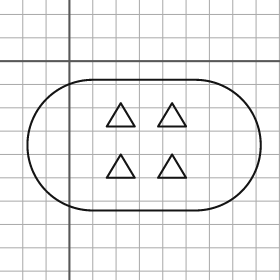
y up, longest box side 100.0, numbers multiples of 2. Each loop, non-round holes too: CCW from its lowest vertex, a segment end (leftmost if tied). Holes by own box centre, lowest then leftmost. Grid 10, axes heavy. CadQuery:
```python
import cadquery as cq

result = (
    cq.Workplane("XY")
    .moveTo(10.0, -64.0)
    .lineTo(54.0, -64.0)
    .threePointArc((82.0, -36.0), (54.0, -8.0))
    .lineTo(10.0, -8.0)
    .threePointArc((-18.0, -36.0), (10.0, -64.0))
    .close()
    .moveTo(16.0, -50.0)
    .lineTo(28.0, -50.0)
    .lineTo(22.0, -40.0)
    .close()
    .moveTo(38.0, -50.0)
    .lineTo(50.0, -50.0)
    .lineTo(44.0, -40.0)
    .close()
    .moveTo(16.0, -28.0)
    .lineTo(28.0, -28.0)
    .lineTo(22.0, -18.0)
    .close()
    .moveTo(38.0, -28.0)
    .lineTo(50.0, -28.0)
    .lineTo(44.0, -18.0)
    .close()
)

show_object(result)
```